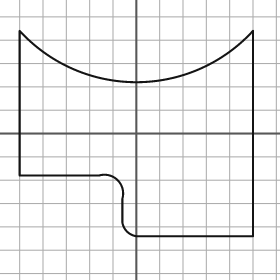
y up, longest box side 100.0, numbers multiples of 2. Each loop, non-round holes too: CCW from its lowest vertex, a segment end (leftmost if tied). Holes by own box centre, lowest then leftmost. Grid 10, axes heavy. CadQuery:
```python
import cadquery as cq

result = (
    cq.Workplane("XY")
    .moveTo(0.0, -44.0)
    .lineTo(50.0, -44.0)
    .lineTo(50.0, 44.0)
    .threePointArc((0.0, 22.0), (-50.0, 44.0))
    .lineTo(-50.0, -18.0)
    .lineTo(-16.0, -18.0)
    .threePointArc((-8.0, -20.0), (-6.0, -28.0))
    .lineTo(-6.0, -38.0)
    .threePointArc((-4.0, -42.0), (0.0, -44.0))
    .close()
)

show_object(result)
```